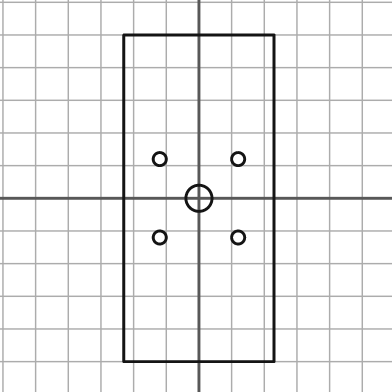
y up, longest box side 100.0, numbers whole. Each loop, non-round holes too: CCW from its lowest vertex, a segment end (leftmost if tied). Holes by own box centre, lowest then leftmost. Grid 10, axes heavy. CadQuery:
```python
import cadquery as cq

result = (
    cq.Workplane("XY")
    .moveTo(-23.0, -50.0)
    .lineTo(23.0, -50.0)
    .lineTo(23.0, 50.0)
    .lineTo(-23.0, 50.0)
    .close()
    .moveTo(-12.0, -12.0)
    .circle(2.0)
    .moveTo(12.0, -12.0)
    .circle(2.0)
    .moveTo(0.0, 0.0)
    .circle(4.0)
    .moveTo(-12.0, 12.0)
    .circle(2.0)
    .moveTo(12.0, 12.0)
    .circle(2.0)
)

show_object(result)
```